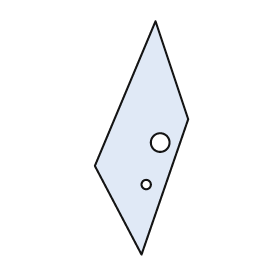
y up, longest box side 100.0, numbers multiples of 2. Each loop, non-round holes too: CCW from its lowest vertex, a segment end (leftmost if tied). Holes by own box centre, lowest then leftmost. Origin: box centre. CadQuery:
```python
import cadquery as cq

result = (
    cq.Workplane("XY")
    .moveTo(0.0, -50.0)
    .lineTo(20.0, 8.0)
    .lineTo(6.0, 50.0)
    .lineTo(-20.0, -12.0)
    .close()
    .moveTo(2.0, -20.0)
    .circle(2.0)
    .moveTo(8.0, -2.0)
    .circle(4.0)
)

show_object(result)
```